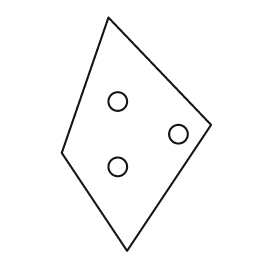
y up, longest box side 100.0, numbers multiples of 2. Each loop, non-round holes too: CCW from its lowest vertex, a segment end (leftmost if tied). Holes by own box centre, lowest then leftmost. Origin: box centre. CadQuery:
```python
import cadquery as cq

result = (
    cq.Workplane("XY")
    .moveTo(-4.0, -50.0)
    .lineTo(32.0, 4.0)
    .lineTo(-12.0, 50.0)
    .lineTo(-32.0, -8.0)
    .close()
    .moveTo(-8.0, -14.0)
    .circle(4.0)
    .moveTo(18.0, 0.0)
    .circle(4.0)
    .moveTo(-8.0, 14.0)
    .circle(4.0)
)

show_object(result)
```